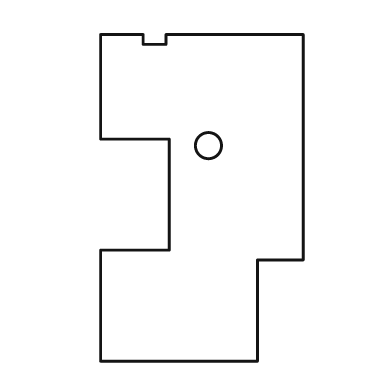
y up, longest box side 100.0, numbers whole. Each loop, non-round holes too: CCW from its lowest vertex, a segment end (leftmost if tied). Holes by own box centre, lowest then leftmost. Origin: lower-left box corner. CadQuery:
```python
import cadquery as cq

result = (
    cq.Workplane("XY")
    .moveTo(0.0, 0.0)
    .lineTo(48.0, 0.0)
    .lineTo(48.0, 31.0)
    .lineTo(62.0, 31.0)
    .lineTo(62.0, 100.0)
    .lineTo(20.0, 100.0)
    .lineTo(20.0, 97.0)
    .lineTo(13.0, 97.0)
    .lineTo(13.0, 100.0)
    .lineTo(0.0, 100.0)
    .lineTo(0.0, 68.0)
    .lineTo(21.0, 68.0)
    .lineTo(21.0, 34.0)
    .lineTo(0.0, 34.0)
    .close()
    .moveTo(33.0, 66.0)
    .circle(4.0)
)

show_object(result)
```